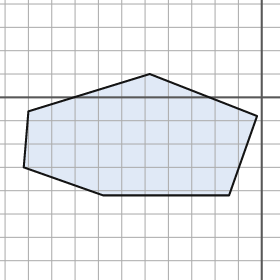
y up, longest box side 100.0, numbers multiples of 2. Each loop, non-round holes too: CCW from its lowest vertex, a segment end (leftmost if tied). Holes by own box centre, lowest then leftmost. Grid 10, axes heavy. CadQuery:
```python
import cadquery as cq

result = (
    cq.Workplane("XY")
    .moveTo(-68.0, -42.0)
    .lineTo(-14.0, -42.0)
    .lineTo(-2.0, -8.0)
    .lineTo(-48.0, 10.0)
    .lineTo(-100.0, -6.0)
    .lineTo(-102.0, -30.0)
    .close()
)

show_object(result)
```